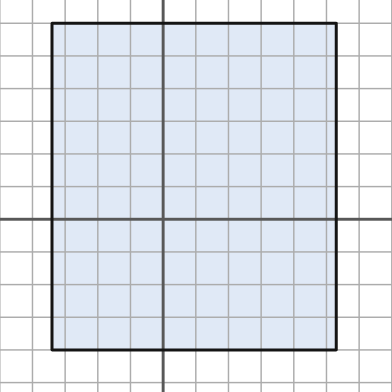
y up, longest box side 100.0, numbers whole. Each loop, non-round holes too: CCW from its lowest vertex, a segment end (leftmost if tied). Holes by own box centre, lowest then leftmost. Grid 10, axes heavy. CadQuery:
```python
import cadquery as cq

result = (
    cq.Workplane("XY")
    .moveTo(-34.0, -40.0)
    .lineTo(53.0, -40.0)
    .lineTo(53.0, 60.0)
    .lineTo(-34.0, 60.0)
    .close()
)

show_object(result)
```